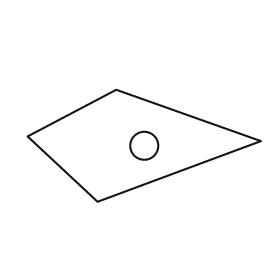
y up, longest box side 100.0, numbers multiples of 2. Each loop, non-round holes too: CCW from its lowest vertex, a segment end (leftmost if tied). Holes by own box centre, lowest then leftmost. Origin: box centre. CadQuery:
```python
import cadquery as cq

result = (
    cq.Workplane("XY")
    .moveTo(-20.0, -24.0)
    .lineTo(50.0, 2.0)
    .lineTo(-12.0, 24.0)
    .lineTo(-50.0, 4.0)
    .close()
    .moveTo(0.0, 0.0)
    .circle(6.0)
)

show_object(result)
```